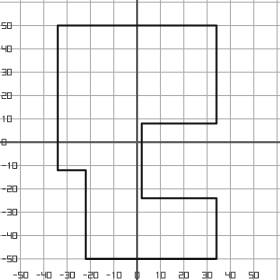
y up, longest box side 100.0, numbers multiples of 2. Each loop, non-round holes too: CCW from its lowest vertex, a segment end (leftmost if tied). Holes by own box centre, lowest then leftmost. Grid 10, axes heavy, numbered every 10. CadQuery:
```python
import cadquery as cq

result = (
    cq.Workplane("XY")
    .moveTo(-22.0, -50.0)
    .lineTo(34.0, -50.0)
    .lineTo(34.0, -24.0)
    .lineTo(2.0, -24.0)
    .lineTo(2.0, 8.0)
    .lineTo(34.0, 8.0)
    .lineTo(34.0, 50.0)
    .lineTo(-34.0, 50.0)
    .lineTo(-34.0, -12.0)
    .lineTo(-22.0, -12.0)
    .close()
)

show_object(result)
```